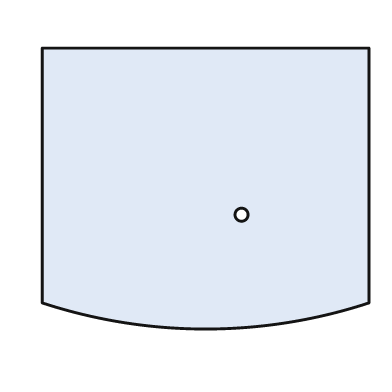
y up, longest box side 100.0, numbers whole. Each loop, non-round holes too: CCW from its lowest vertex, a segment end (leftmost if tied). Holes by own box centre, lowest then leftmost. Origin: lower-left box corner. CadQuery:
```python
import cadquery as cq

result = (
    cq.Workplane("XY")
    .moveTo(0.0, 8.0)
    .threePointArc((50.0, 0.0), (100.0, 8.0))
    .lineTo(100.0, 86.0)
    .lineTo(0.0, 86.0)
    .close()
    .moveTo(61.0, 35.0)
    .circle(2.0)
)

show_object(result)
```